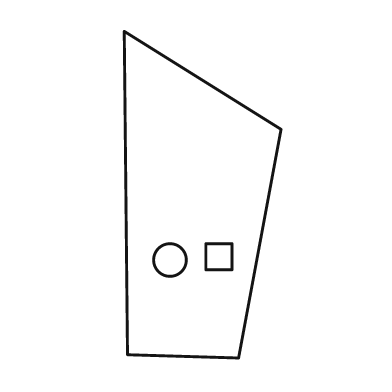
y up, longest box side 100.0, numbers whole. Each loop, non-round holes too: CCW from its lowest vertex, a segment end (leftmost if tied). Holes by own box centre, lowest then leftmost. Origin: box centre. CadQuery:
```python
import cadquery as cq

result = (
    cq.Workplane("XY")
    .moveTo(11.0, -50.0)
    .lineTo(24.0, 20.0)
    .lineTo(-24.0, 50.0)
    .lineTo(-23.0, -49.0)
    .close()
    .moveTo(-10.0, -20.0)
    .circle(5.0)
    .moveTo(1.0, -23.0)
    .lineTo(9.0, -23.0)
    .lineTo(9.0, -15.0)
    .lineTo(1.0, -15.0)
    .close()
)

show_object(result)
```